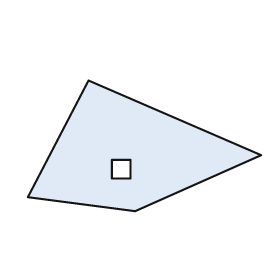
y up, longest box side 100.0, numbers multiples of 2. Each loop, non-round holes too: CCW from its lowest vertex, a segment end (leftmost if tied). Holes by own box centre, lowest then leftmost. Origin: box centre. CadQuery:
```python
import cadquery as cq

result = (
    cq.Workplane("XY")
    .moveTo(-4.0, -28.0)
    .lineTo(50.0, -4.0)
    .lineTo(-24.0, 28.0)
    .lineTo(-50.0, -22.0)
    .close()
    .moveTo(-14.0, -14.0)
    .lineTo(-6.0, -14.0)
    .lineTo(-6.0, -6.0)
    .lineTo(-14.0, -6.0)
    .close()
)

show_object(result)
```